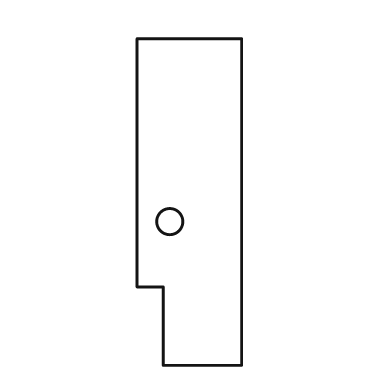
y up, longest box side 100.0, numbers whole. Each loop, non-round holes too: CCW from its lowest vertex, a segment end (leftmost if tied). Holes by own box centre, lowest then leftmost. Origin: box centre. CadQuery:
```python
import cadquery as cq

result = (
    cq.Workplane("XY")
    .moveTo(-8.0, -50.0)
    .lineTo(16.0, -50.0)
    .lineTo(16.0, 50.0)
    .lineTo(-16.0, 50.0)
    .lineTo(-16.0, -26.0)
    .lineTo(-8.0, -26.0)
    .close()
    .moveTo(-6.0, -6.0)
    .circle(4.0)
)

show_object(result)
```